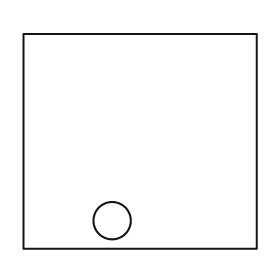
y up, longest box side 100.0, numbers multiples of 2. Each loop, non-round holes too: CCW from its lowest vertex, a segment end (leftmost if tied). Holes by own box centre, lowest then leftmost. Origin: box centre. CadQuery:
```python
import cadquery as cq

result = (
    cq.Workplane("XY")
    .moveTo(-50.0, -46.0)
    .lineTo(50.0, -46.0)
    .lineTo(50.0, 46.0)
    .lineTo(-50.0, 46.0)
    .close()
    .moveTo(-12.0, -34.0)
    .circle(8.0)
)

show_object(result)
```